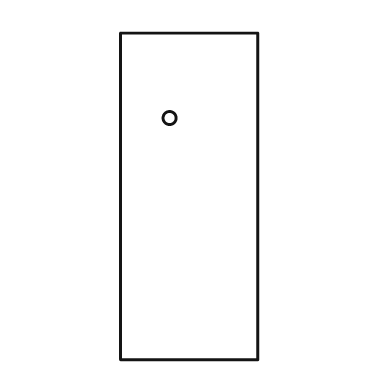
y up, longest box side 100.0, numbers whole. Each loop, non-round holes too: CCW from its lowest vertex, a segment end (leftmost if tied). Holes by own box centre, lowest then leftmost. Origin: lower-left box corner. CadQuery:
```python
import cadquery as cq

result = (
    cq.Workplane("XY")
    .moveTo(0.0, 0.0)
    .lineTo(42.0, 0.0)
    .lineTo(42.0, 100.0)
    .lineTo(0.0, 100.0)
    .close()
    .moveTo(15.0, 74.0)
    .circle(2.0)
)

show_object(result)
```